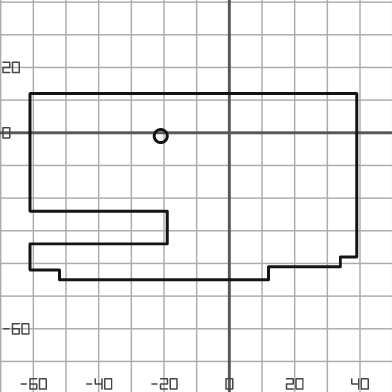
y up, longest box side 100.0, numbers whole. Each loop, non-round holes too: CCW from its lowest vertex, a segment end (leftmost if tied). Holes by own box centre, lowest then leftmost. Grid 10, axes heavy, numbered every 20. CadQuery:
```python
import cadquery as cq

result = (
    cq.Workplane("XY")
    .moveTo(-52.0, -45.0)
    .lineTo(12.0, -45.0)
    .lineTo(12.0, -41.0)
    .lineTo(34.0, -41.0)
    .lineTo(34.0, -38.0)
    .lineTo(39.0, -38.0)
    .lineTo(39.0, 12.0)
    .lineTo(-61.0, 12.0)
    .lineTo(-61.0, -24.0)
    .lineTo(-19.0, -24.0)
    .lineTo(-19.0, -34.0)
    .lineTo(-61.0, -34.0)
    .lineTo(-61.0, -42.0)
    .lineTo(-52.0, -42.0)
    .close()
    .moveTo(-21.0, -1.0)
    .circle(2.0)
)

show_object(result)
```